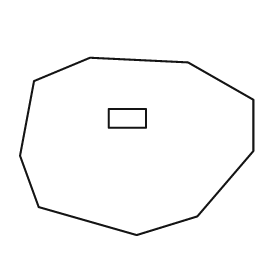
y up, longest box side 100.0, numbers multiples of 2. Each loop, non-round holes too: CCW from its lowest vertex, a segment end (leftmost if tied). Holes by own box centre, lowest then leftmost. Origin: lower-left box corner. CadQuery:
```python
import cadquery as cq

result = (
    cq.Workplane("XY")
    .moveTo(50.0, 0.0)
    .lineTo(76.0, 8.0)
    .lineTo(100.0, 36.0)
    .lineTo(100.0, 58.0)
    .lineTo(72.0, 74.0)
    .lineTo(30.0, 76.0)
    .lineTo(6.0, 66.0)
    .lineTo(0.0, 34.0)
    .lineTo(8.0, 12.0)
    .close()
    .moveTo(38.0, 46.0)
    .lineTo(54.0, 46.0)
    .lineTo(54.0, 54.0)
    .lineTo(38.0, 54.0)
    .close()
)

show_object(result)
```